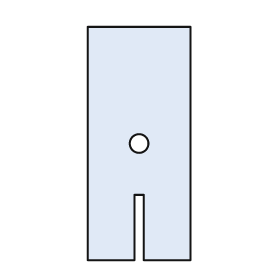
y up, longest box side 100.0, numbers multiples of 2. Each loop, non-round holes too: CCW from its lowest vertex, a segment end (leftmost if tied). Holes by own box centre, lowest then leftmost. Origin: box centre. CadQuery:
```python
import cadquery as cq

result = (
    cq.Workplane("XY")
    .moveTo(-22.0, -50.0)
    .lineTo(-2.0, -50.0)
    .lineTo(-2.0, -22.0)
    .lineTo(2.0, -22.0)
    .lineTo(2.0, -50.0)
    .lineTo(22.0, -50.0)
    .lineTo(22.0, 50.0)
    .lineTo(-22.0, 50.0)
    .close()
    .moveTo(0.0, 0.0)
    .circle(4.0)
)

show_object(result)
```